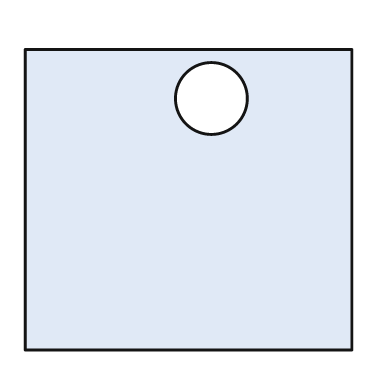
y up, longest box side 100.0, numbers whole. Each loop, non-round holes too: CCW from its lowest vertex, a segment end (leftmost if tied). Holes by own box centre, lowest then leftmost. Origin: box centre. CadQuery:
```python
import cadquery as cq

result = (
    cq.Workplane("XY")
    .moveTo(-50.0, -46.0)
    .lineTo(50.0, -46.0)
    .lineTo(50.0, 46.0)
    .lineTo(-50.0, 46.0)
    .close()
    .moveTo(7.0, 31.0)
    .circle(11.0)
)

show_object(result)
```